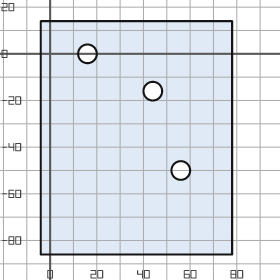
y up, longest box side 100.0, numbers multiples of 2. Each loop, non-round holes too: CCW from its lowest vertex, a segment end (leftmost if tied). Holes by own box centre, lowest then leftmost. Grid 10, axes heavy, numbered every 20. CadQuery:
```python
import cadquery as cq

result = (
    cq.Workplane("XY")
    .moveTo(-4.0, -86.0)
    .lineTo(78.0, -86.0)
    .lineTo(78.0, 14.0)
    .lineTo(-4.0, 14.0)
    .close()
    .moveTo(56.0, -50.0)
    .circle(4.0)
    .moveTo(44.0, -16.0)
    .circle(4.0)
    .moveTo(16.0, 0.0)
    .circle(4.0)
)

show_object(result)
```